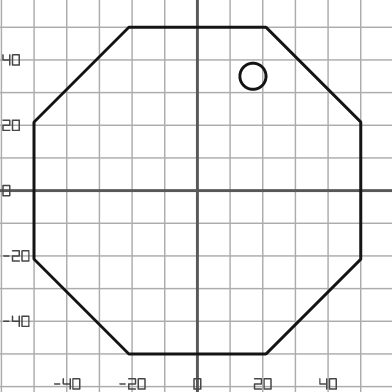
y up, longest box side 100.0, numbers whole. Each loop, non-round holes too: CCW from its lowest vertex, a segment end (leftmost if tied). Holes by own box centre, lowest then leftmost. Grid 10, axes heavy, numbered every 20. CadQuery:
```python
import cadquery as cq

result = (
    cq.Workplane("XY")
    .moveTo(-21.0, -50.0)
    .lineTo(21.0, -50.0)
    .lineTo(50.0, -21.0)
    .lineTo(50.0, 21.0)
    .lineTo(21.0, 50.0)
    .lineTo(-21.0, 50.0)
    .lineTo(-50.0, 21.0)
    .lineTo(-50.0, -21.0)
    .close()
    .moveTo(17.0, 35.0)
    .circle(4.0)
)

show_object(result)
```